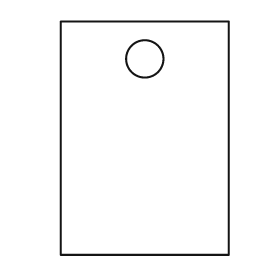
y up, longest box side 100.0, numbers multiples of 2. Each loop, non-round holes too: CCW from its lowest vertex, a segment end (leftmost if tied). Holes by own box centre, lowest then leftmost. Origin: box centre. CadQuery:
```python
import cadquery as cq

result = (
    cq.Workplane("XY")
    .moveTo(-36.0, -50.0)
    .lineTo(36.0, -50.0)
    .lineTo(36.0, 50.0)
    .lineTo(-36.0, 50.0)
    .close()
    .moveTo(0.0, 34.0)
    .circle(8.0)
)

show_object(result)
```